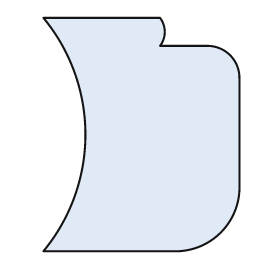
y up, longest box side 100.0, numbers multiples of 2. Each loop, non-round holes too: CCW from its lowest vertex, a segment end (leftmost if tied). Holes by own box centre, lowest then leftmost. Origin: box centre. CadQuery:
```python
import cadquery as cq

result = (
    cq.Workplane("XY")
    .moveTo(-42.0, -50.0)
    .lineTo(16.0, -50.0)
    .threePointArc((34.0, -42.0), (42.0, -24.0))
    .lineTo(42.0, 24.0)
    .threePointArc((38.0, 34.0), (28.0, 38.0))
    .lineTo(8.0, 38.0)
    .threePointArc((10.0, 44.0), (8.0, 50.0))
    .lineTo(-42.0, 50.0)
    .threePointArc((-24.0, 0.0), (-42.0, -50.0))
    .close()
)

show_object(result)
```